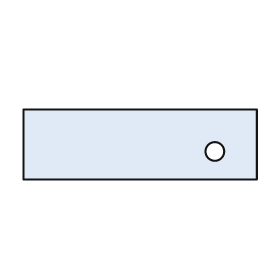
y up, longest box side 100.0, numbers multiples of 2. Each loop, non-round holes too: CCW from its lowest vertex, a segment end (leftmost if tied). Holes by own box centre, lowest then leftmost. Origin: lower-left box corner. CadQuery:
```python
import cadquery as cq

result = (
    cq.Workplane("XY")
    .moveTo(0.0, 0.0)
    .lineTo(100.0, 0.0)
    .lineTo(100.0, 30.0)
    .lineTo(0.0, 30.0)
    .close()
    .moveTo(82.0, 12.0)
    .circle(4.0)
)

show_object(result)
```